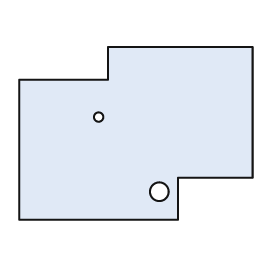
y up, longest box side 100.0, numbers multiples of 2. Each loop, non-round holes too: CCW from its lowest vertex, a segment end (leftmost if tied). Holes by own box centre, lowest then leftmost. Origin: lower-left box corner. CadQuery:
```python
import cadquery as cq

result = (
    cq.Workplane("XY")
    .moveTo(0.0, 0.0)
    .lineTo(68.0, 0.0)
    .lineTo(68.0, 18.0)
    .lineTo(100.0, 18.0)
    .lineTo(100.0, 74.0)
    .lineTo(38.0, 74.0)
    .lineTo(38.0, 60.0)
    .lineTo(0.0, 60.0)
    .close()
    .moveTo(60.0, 12.0)
    .circle(4.0)
    .moveTo(34.0, 44.0)
    .circle(2.0)
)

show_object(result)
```